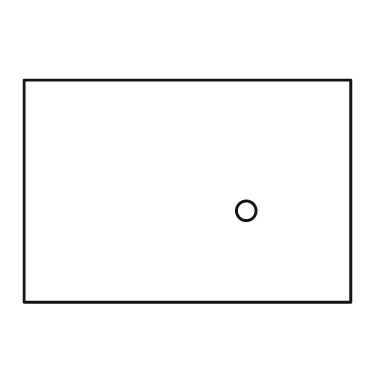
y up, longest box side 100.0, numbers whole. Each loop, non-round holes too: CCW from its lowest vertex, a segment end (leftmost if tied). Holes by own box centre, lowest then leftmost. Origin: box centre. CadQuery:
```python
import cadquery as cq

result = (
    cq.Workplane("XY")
    .moveTo(-50.0, -34.0)
    .lineTo(50.0, -34.0)
    .lineTo(50.0, 34.0)
    .lineTo(-50.0, 34.0)
    .close()
    .moveTo(18.0, -6.0)
    .circle(3.0)
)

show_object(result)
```